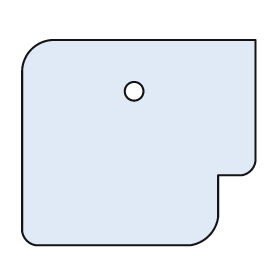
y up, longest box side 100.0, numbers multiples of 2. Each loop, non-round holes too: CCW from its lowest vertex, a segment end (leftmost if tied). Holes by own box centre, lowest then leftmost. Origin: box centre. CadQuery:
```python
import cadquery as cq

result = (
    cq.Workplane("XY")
    .moveTo(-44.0, -44.0)
    .lineTo(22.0, -44.0)
    .threePointArc((30.0, -40.0), (34.0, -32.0))
    .lineTo(34.0, -14.0)
    .lineTo(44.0, -14.0)
    .threePointArc((48.0, -12.0), (50.0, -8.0))
    .lineTo(50.0, 44.0)
    .lineTo(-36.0, 44.0)
    .threePointArc((-46.0, 40.0), (-50.0, 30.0))
    .lineTo(-50.0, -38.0)
    .threePointArc((-48.0, -42.0), (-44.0, -44.0))
    .close()
    .moveTo(-2.0, 22.0)
    .circle(4.0)
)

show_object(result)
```